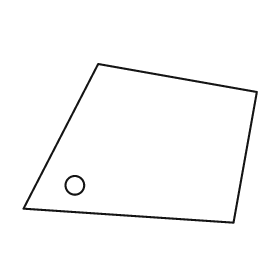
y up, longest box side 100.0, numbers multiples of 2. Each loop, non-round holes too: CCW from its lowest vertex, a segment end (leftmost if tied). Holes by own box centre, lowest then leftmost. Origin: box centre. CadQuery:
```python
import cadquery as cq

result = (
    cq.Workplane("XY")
    .moveTo(40.0, -34.0)
    .lineTo(50.0, 22.0)
    .lineTo(-18.0, 34.0)
    .lineTo(-50.0, -28.0)
    .close()
    .moveTo(-28.0, -18.0)
    .circle(4.0)
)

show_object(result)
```